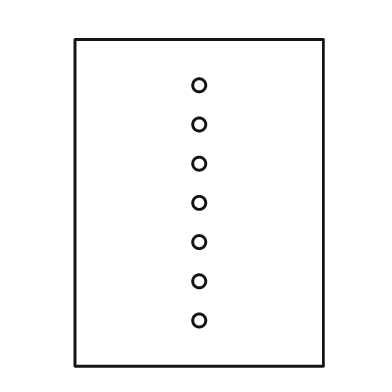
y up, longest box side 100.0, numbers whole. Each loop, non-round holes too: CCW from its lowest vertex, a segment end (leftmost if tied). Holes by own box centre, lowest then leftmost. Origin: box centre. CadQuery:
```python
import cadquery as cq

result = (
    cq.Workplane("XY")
    .moveTo(-38.0, -50.0)
    .lineTo(38.0, -50.0)
    .lineTo(38.0, 50.0)
    .lineTo(-38.0, 50.0)
    .close()
    .moveTo(0.0, -36.0)
    .circle(2.0)
    .moveTo(0.0, -24.0)
    .circle(2.0)
    .moveTo(0.0, -12.0)
    .circle(2.0)
    .moveTo(0.0, 0.0)
    .circle(2.0)
    .moveTo(0.0, 12.0)
    .circle(2.0)
    .moveTo(0.0, 24.0)
    .circle(2.0)
    .moveTo(0.0, 36.0)
    .circle(2.0)
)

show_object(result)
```